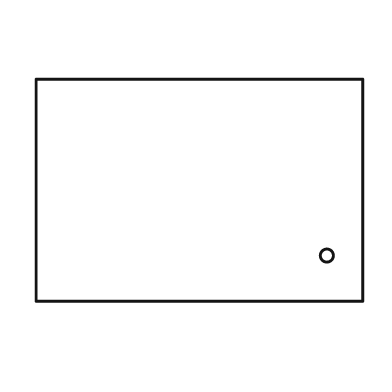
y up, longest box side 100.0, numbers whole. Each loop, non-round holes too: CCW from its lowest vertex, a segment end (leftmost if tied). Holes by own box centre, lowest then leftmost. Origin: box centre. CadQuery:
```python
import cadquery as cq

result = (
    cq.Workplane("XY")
    .moveTo(-50.0, -34.0)
    .lineTo(50.0, -34.0)
    .lineTo(50.0, 34.0)
    .lineTo(-50.0, 34.0)
    .close()
    .moveTo(39.0, -20.0)
    .circle(2.0)
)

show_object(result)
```